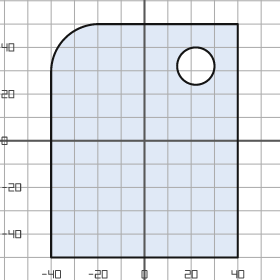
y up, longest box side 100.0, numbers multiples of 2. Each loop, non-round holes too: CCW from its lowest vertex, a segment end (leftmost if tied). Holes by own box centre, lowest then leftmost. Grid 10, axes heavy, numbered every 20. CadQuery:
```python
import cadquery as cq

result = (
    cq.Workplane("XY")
    .moveTo(-40.0, -50.0)
    .lineTo(40.0, -50.0)
    .lineTo(40.0, 50.0)
    .lineTo(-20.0, 50.0)
    .threePointArc((-34.0, 44.0), (-40.0, 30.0))
    .close()
    .moveTo(22.0, 32.0)
    .circle(8.0)
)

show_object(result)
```